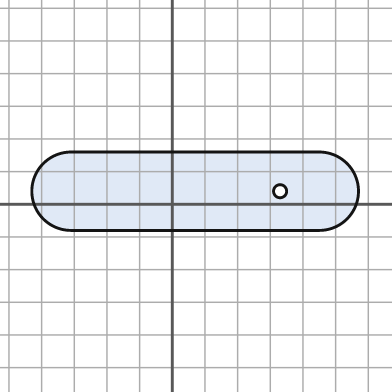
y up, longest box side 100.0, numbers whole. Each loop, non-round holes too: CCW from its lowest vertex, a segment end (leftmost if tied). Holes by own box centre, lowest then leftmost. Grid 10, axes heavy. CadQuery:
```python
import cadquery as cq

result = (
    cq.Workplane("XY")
    .moveTo(-31.0, -8.0)
    .lineTo(45.0, -8.0)
    .threePointArc((57.0, 4.0), (45.0, 16.0))
    .lineTo(-31.0, 16.0)
    .threePointArc((-43.0, 4.0), (-31.0, -8.0))
    .close()
    .moveTo(33.0, 4.0)
    .circle(2.0)
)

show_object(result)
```